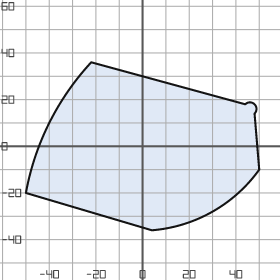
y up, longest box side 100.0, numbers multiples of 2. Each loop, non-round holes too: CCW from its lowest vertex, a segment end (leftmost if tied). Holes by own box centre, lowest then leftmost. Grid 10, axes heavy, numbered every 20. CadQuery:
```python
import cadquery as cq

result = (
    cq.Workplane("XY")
    .moveTo(4.0, -36.0)
    .threePointArc((30.0, -28.0), (50.0, -10.0))
    .lineTo(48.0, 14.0)
    .threePointArc((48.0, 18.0), (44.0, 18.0))
    .lineTo(-22.0, 36.0)
    .threePointArc((-40.0, 10.0), (-50.0, -20.0))
    .close()
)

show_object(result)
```